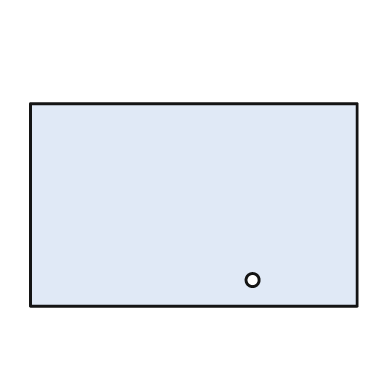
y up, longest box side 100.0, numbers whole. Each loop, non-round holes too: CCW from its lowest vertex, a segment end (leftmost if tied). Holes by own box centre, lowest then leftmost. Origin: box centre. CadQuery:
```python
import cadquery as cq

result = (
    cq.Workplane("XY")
    .moveTo(-50.0, -31.0)
    .lineTo(50.0, -31.0)
    .lineTo(50.0, 31.0)
    .lineTo(-50.0, 31.0)
    .close()
    .moveTo(18.0, -23.0)
    .circle(2.0)
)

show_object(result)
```